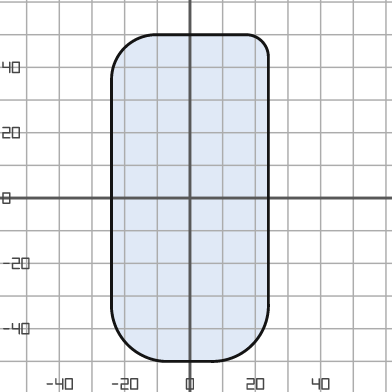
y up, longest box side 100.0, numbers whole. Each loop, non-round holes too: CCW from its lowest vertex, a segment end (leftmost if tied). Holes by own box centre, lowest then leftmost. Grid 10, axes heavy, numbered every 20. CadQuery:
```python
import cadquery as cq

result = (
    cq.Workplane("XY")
    .moveTo(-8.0, -50.0)
    .lineTo(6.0, -50.0)
    .threePointArc((19.0, -45.0), (24.0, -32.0))
    .lineTo(24.0, 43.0)
    .threePointArc((22.0, 48.0), (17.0, 50.0))
    .lineTo(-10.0, 50.0)
    .threePointArc((-20.0, 46.0), (-24.0, 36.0))
    .lineTo(-24.0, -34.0)
    .threePointArc((-19.0, -45.0), (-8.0, -50.0))
    .close()
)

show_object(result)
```